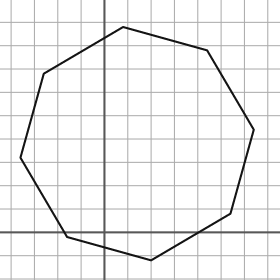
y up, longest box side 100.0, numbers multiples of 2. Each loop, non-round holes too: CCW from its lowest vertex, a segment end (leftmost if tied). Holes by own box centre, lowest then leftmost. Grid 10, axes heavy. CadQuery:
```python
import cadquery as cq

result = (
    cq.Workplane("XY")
    .moveTo(20.0, -12.0)
    .lineTo(54.0, 8.0)
    .lineTo(64.0, 44.0)
    .lineTo(44.0, 78.0)
    .lineTo(8.0, 88.0)
    .lineTo(-26.0, 68.0)
    .lineTo(-36.0, 32.0)
    .lineTo(-16.0, -2.0)
    .close()
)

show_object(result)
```